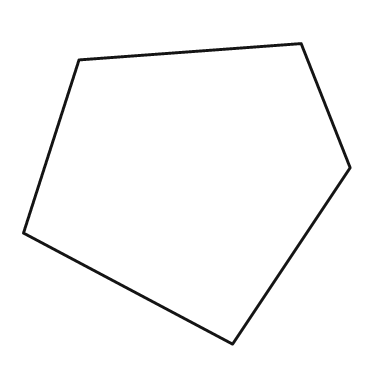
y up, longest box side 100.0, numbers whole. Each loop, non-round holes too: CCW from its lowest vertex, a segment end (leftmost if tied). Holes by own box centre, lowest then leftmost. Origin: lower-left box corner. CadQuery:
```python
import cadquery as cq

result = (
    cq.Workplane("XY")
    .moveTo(64.0, 0.0)
    .lineTo(100.0, 54.0)
    .lineTo(85.0, 92.0)
    .lineTo(17.0, 87.0)
    .lineTo(0.0, 34.0)
    .close()
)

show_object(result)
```